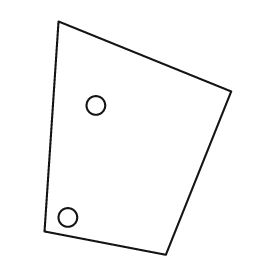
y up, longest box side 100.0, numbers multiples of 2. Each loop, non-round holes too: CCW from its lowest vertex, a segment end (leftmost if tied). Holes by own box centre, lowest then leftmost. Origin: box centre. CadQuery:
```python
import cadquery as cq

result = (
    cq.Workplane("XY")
    .moveTo(12.0, -50.0)
    .lineTo(40.0, 20.0)
    .lineTo(-34.0, 50.0)
    .lineTo(-40.0, -40.0)
    .close()
    .moveTo(-30.0, -34.0)
    .circle(4.0)
    .moveTo(-18.0, 14.0)
    .circle(4.0)
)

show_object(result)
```